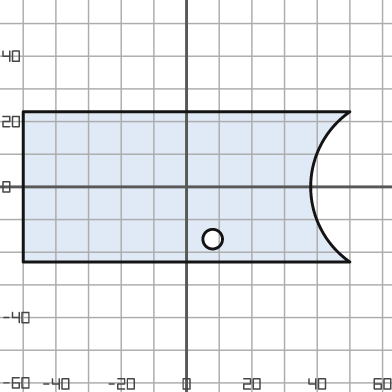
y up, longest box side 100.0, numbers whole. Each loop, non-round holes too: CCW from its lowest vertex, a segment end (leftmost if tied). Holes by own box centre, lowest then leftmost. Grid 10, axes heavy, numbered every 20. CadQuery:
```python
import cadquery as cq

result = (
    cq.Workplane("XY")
    .moveTo(-50.0, -23.0)
    .lineTo(50.0, -23.0)
    .threePointArc((38.0, 0.0), (50.0, 23.0))
    .lineTo(-50.0, 23.0)
    .close()
    .moveTo(8.0, -16.0)
    .circle(3.0)
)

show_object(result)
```